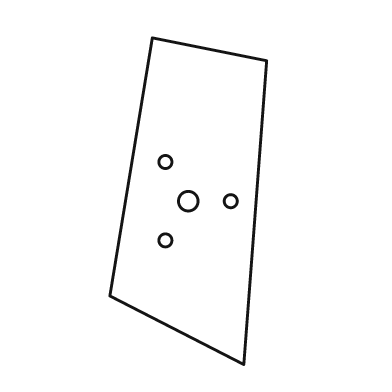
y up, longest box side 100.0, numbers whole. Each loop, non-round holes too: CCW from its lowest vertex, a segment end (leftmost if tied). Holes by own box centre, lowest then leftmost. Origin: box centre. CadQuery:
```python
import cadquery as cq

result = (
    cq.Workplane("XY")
    .moveTo(17.0, -50.0)
    .lineTo(24.0, 43.0)
    .lineTo(-11.0, 50.0)
    .lineTo(-24.0, -29.0)
    .close()
    .moveTo(-7.0, -12.0)
    .circle(2.0)
    .moveTo(0.0, 0.0)
    .circle(3.0)
    .moveTo(13.0, 0.0)
    .circle(2.0)
    .moveTo(-7.0, 12.0)
    .circle(2.0)
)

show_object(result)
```